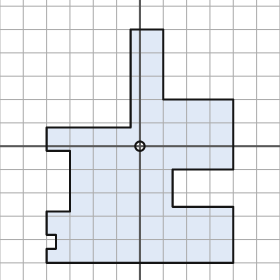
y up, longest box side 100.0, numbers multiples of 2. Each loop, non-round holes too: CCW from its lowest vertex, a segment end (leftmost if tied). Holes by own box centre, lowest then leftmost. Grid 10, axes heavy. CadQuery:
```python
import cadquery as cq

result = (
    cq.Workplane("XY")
    .moveTo(-40.0, -50.0)
    .lineTo(40.0, -50.0)
    .lineTo(40.0, -26.0)
    .lineTo(14.0, -26.0)
    .lineTo(14.0, -10.0)
    .lineTo(40.0, -10.0)
    .lineTo(40.0, 20.0)
    .lineTo(10.0, 20.0)
    .lineTo(10.0, 50.0)
    .lineTo(-4.0, 50.0)
    .lineTo(-4.0, 8.0)
    .lineTo(-40.0, 8.0)
    .lineTo(-40.0, -2.0)
    .lineTo(-30.0, -2.0)
    .lineTo(-30.0, -28.0)
    .lineTo(-40.0, -28.0)
    .lineTo(-40.0, -38.0)
    .lineTo(-36.0, -38.0)
    .lineTo(-36.0, -44.0)
    .lineTo(-40.0, -44.0)
    .close()
    .moveTo(0.0, 0.0)
    .circle(2.0)
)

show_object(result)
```